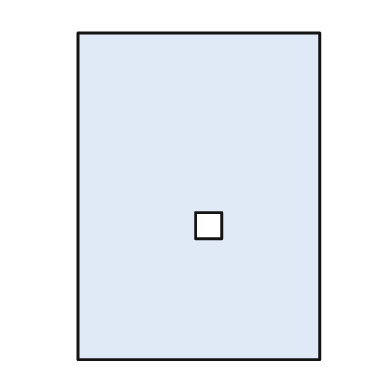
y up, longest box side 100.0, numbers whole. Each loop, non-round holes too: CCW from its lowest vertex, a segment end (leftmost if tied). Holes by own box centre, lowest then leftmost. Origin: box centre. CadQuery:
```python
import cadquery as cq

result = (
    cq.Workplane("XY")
    .moveTo(-37.0, -50.0)
    .lineTo(37.0, -50.0)
    .lineTo(37.0, 50.0)
    .lineTo(-37.0, 50.0)
    .close()
    .moveTo(-1.0, -13.0)
    .lineTo(7.0, -13.0)
    .lineTo(7.0, -5.0)
    .lineTo(-1.0, -5.0)
    .close()
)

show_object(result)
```